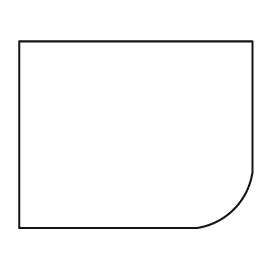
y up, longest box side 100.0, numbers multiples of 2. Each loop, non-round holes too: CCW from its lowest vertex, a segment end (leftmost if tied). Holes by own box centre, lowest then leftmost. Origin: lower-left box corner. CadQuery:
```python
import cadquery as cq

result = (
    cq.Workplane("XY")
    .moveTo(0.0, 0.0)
    .lineTo(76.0, 0.0)
    .threePointArc((92.0, 8.0), (100.0, 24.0))
    .lineTo(100.0, 80.0)
    .lineTo(0.0, 80.0)
    .close()
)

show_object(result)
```